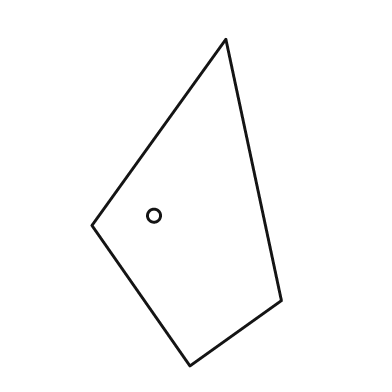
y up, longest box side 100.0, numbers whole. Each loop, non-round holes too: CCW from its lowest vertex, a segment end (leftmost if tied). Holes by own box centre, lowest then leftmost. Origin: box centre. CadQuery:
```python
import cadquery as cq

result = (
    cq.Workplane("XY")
    .moveTo(1.0, -50.0)
    .lineTo(29.0, -30.0)
    .lineTo(12.0, 50.0)
    .lineTo(-29.0, -7.0)
    .close()
    .moveTo(-10.0, -4.0)
    .circle(2.0)
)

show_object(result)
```